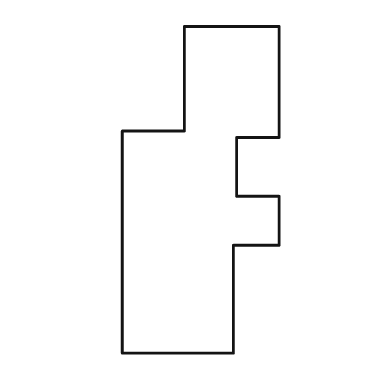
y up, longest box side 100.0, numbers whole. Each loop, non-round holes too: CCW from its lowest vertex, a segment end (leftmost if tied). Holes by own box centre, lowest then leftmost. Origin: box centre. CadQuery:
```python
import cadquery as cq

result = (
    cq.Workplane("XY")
    .moveTo(-24.0, -50.0)
    .lineTo(10.0, -50.0)
    .lineTo(10.0, -17.0)
    .lineTo(24.0, -17.0)
    .lineTo(24.0, -2.0)
    .lineTo(11.0, -2.0)
    .lineTo(11.0, 16.0)
    .lineTo(24.0, 16.0)
    .lineTo(24.0, 50.0)
    .lineTo(-5.0, 50.0)
    .lineTo(-5.0, 18.0)
    .lineTo(-24.0, 18.0)
    .close()
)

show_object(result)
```